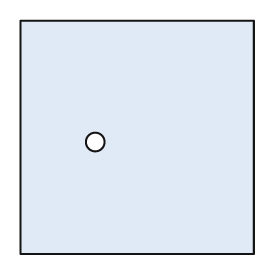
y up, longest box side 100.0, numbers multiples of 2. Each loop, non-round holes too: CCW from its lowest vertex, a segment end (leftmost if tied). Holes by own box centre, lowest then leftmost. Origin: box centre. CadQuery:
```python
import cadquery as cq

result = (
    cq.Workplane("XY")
    .moveTo(-50.0, -50.0)
    .lineTo(50.0, -50.0)
    .lineTo(50.0, 50.0)
    .lineTo(-50.0, 50.0)
    .close()
    .moveTo(-18.0, -2.0)
    .circle(4.0)
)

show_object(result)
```